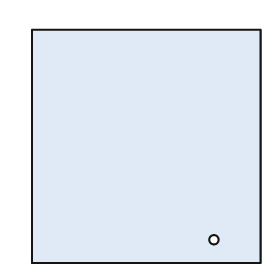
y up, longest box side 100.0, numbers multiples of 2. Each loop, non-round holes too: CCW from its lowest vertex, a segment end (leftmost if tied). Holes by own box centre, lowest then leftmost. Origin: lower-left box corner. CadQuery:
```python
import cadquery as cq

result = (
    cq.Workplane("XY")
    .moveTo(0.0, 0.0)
    .lineTo(98.0, 0.0)
    .lineTo(98.0, 100.0)
    .lineTo(0.0, 100.0)
    .close()
    .moveTo(78.0, 10.0)
    .circle(2.0)
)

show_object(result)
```